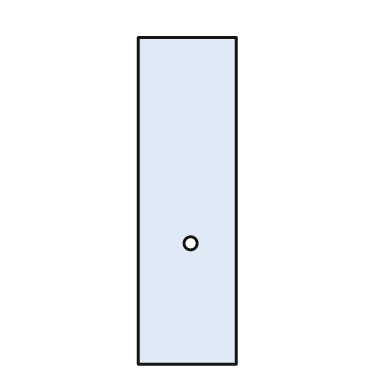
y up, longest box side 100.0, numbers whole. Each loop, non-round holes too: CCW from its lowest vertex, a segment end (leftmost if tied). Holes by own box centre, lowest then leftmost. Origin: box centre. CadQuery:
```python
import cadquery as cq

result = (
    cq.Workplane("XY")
    .moveTo(-15.0, -50.0)
    .lineTo(15.0, -50.0)
    .lineTo(15.0, 50.0)
    .lineTo(-15.0, 50.0)
    .close()
    .moveTo(1.0, -13.0)
    .circle(2.0)
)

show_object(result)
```